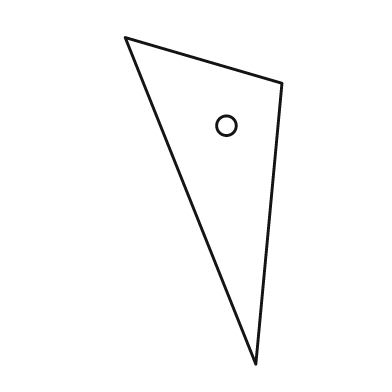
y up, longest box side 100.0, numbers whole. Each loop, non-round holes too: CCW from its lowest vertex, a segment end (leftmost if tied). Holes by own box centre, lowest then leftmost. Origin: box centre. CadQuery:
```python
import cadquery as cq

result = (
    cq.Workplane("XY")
    .moveTo(16.0, -50.0)
    .lineTo(24.0, 36.0)
    .lineTo(-24.0, 50.0)
    .close()
    .moveTo(7.0, 23.0)
    .circle(3.0)
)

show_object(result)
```